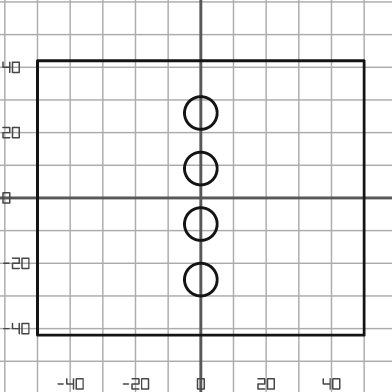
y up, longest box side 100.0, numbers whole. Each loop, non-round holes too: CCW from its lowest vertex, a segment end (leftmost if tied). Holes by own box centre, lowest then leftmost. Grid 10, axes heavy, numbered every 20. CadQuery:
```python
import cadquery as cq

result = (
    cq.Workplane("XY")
    .moveTo(-50.0, -42.0)
    .lineTo(50.0, -42.0)
    .lineTo(50.0, 42.0)
    .lineTo(-50.0, 42.0)
    .close()
    .moveTo(0.0, -25.0)
    .circle(5.0)
    .moveTo(0.0, -8.0)
    .circle(5.0)
    .moveTo(0.0, 9.0)
    .circle(5.0)
    .moveTo(0.0, 26.0)
    .circle(5.0)
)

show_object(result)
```